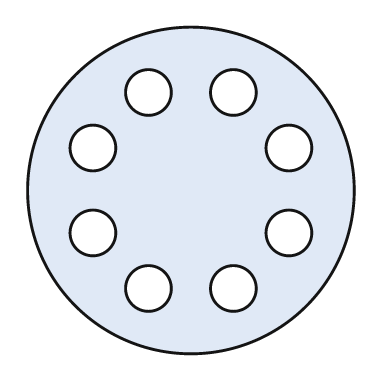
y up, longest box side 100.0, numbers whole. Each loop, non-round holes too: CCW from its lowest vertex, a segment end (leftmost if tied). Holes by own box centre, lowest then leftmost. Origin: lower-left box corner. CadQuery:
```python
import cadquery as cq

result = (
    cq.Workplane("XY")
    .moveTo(50.0, 50.0)
    .circle(50.0)
    .moveTo(37.0, 20.0)
    .circle(7.0)
    .moveTo(63.0, 20.0)
    .circle(7.0)
    .moveTo(20.0, 37.0)
    .circle(7.0)
    .moveTo(80.0, 37.0)
    .circle(7.0)
    .moveTo(20.0, 63.0)
    .circle(7.0)
    .moveTo(80.0, 63.0)
    .circle(7.0)
    .moveTo(37.0, 80.0)
    .circle(7.0)
    .moveTo(63.0, 80.0)
    .circle(7.0)
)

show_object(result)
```